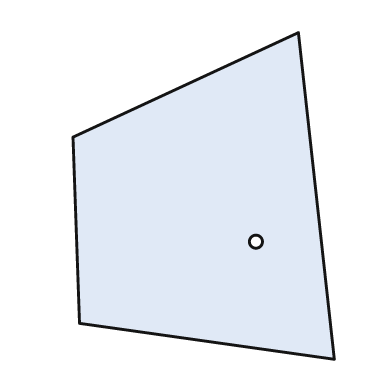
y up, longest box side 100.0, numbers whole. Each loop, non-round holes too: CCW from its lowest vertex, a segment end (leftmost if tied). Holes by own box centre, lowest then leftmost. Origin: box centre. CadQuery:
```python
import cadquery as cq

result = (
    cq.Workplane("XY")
    .moveTo(40.0, -50.0)
    .lineTo(29.0, 50.0)
    .lineTo(-40.0, 18.0)
    .lineTo(-38.0, -39.0)
    .close()
    .moveTo(16.0, -14.0)
    .circle(2.0)
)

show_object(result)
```